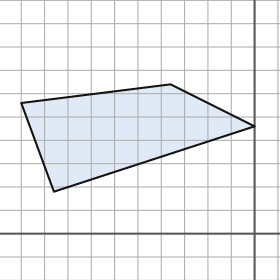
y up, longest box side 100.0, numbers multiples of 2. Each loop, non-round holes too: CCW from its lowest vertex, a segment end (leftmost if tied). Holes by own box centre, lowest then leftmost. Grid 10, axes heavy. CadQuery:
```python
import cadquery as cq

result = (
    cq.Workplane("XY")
    .moveTo(-86.0, 18.0)
    .lineTo(0.0, 46.0)
    .lineTo(-36.0, 64.0)
    .lineTo(-100.0, 56.0)
    .close()
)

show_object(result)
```